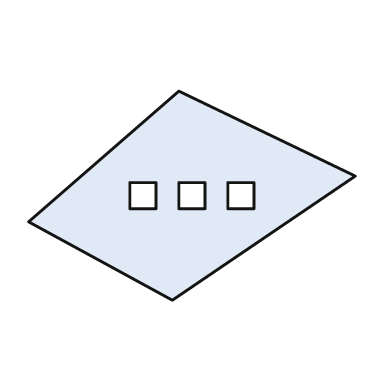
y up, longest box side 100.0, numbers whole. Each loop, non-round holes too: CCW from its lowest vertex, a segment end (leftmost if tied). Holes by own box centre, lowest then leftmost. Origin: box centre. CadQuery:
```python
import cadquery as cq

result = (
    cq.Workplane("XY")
    .moveTo(-6.0, -32.0)
    .lineTo(50.0, 6.0)
    .lineTo(-4.0, 32.0)
    .lineTo(-50.0, -8.0)
    .close()
    .moveTo(-19.0, -4.0)
    .lineTo(-11.0, -4.0)
    .lineTo(-11.0, 4.0)
    .lineTo(-19.0, 4.0)
    .close()
    .moveTo(-4.0, -4.0)
    .lineTo(4.0, -4.0)
    .lineTo(4.0, 4.0)
    .lineTo(-4.0, 4.0)
    .close()
    .moveTo(11.0, -4.0)
    .lineTo(19.0, -4.0)
    .lineTo(19.0, 4.0)
    .lineTo(11.0, 4.0)
    .close()
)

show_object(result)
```